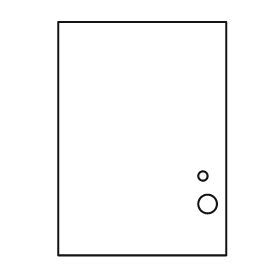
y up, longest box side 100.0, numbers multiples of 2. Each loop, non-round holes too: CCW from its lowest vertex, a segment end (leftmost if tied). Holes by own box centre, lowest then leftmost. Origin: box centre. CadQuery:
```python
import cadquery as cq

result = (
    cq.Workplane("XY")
    .moveTo(-36.0, -50.0)
    .lineTo(36.0, -50.0)
    .lineTo(36.0, 50.0)
    .lineTo(-36.0, 50.0)
    .close()
    .moveTo(28.0, -28.0)
    .circle(4.0)
    .moveTo(26.0, -16.0)
    .circle(2.0)
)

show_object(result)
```